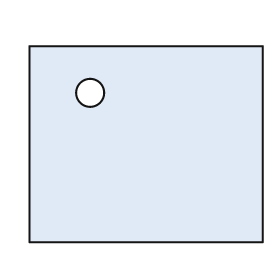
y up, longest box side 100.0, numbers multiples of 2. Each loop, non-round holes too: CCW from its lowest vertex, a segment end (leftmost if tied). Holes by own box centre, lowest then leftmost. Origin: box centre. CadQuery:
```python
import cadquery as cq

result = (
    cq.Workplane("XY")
    .moveTo(-50.0, -42.0)
    .lineTo(50.0, -42.0)
    .lineTo(50.0, 42.0)
    .lineTo(-50.0, 42.0)
    .close()
    .moveTo(-24.0, 22.0)
    .circle(6.0)
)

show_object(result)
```